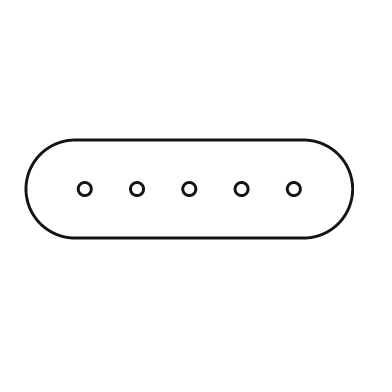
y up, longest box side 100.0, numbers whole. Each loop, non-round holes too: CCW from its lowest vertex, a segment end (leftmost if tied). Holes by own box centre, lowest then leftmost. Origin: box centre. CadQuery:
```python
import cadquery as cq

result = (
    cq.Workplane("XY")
    .moveTo(-35.0, -15.0)
    .lineTo(35.0, -15.0)
    .threePointArc((50.0, 0.0), (35.0, 15.0))
    .lineTo(-35.0, 15.0)
    .threePointArc((-50.0, 0.0), (-35.0, -15.0))
    .close()
    .moveTo(-32.0, 0.0)
    .circle(2.0)
    .moveTo(-16.0, 0.0)
    .circle(2.0)
    .moveTo(0.0, 0.0)
    .circle(2.0)
    .moveTo(16.0, 0.0)
    .circle(2.0)
    .moveTo(32.0, 0.0)
    .circle(2.0)
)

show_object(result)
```